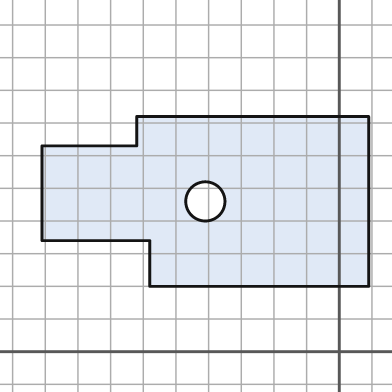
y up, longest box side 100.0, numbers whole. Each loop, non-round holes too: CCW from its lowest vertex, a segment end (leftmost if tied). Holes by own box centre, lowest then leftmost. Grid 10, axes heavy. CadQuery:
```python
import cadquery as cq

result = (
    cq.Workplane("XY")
    .moveTo(-58.0, 20.0)
    .lineTo(9.0, 20.0)
    .lineTo(9.0, 72.0)
    .lineTo(-62.0, 72.0)
    .lineTo(-62.0, 63.0)
    .lineTo(-91.0, 63.0)
    .lineTo(-91.0, 34.0)
    .lineTo(-58.0, 34.0)
    .close()
    .moveTo(-41.0, 46.0)
    .circle(6.0)
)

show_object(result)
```